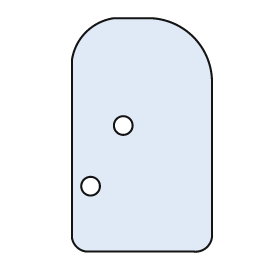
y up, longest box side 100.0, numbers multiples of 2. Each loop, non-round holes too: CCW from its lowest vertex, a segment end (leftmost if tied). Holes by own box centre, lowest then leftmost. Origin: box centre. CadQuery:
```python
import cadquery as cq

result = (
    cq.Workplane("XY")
    .moveTo(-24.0, -50.0)
    .lineTo(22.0, -50.0)
    .threePointArc((28.0, -48.0), (30.0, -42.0))
    .lineTo(30.0, 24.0)
    .threePointArc((22.0, 42.0), (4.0, 50.0))
    .lineTo(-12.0, 50.0)
    .threePointArc((-24.0, 44.0), (-30.0, 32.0))
    .lineTo(-30.0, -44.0)
    .threePointArc((-28.0, -48.0), (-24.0, -50.0))
    .close()
    .moveTo(-22.0, -22.0)
    .circle(4.0)
    .moveTo(-8.0, 4.0)
    .circle(4.0)
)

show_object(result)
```